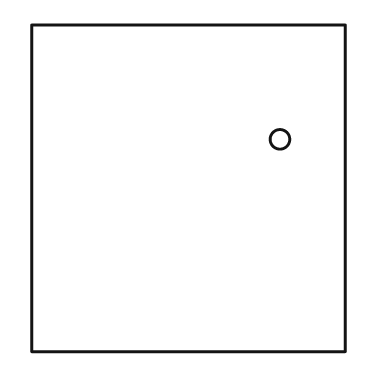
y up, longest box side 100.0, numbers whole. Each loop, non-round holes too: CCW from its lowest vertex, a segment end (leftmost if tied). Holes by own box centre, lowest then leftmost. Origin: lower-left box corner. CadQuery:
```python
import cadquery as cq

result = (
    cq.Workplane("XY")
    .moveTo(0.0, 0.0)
    .lineTo(96.0, 0.0)
    .lineTo(96.0, 100.0)
    .lineTo(0.0, 100.0)
    .close()
    .moveTo(76.0, 65.0)
    .circle(3.0)
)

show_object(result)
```